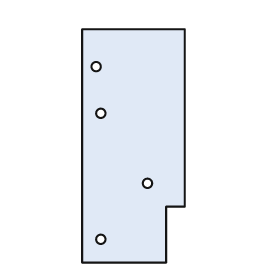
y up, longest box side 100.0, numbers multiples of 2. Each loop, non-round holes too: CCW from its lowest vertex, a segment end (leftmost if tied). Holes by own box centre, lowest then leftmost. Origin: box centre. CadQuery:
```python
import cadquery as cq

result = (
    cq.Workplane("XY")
    .moveTo(-22.0, -50.0)
    .lineTo(14.0, -50.0)
    .lineTo(14.0, -26.0)
    .lineTo(22.0, -26.0)
    .lineTo(22.0, 50.0)
    .lineTo(-22.0, 50.0)
    .close()
    .moveTo(-14.0, -40.0)
    .circle(2.0)
    .moveTo(6.0, -16.0)
    .circle(2.0)
    .moveTo(-14.0, 14.0)
    .circle(2.0)
    .moveTo(-16.0, 34.0)
    .circle(2.0)
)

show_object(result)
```